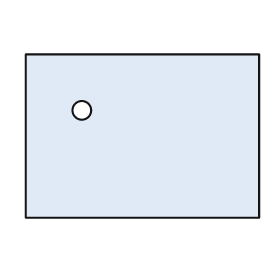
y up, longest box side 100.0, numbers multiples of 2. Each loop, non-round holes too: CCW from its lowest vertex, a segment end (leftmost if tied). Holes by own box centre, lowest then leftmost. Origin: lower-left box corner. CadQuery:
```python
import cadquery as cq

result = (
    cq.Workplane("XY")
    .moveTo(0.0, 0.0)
    .lineTo(100.0, 0.0)
    .lineTo(100.0, 70.0)
    .lineTo(0.0, 70.0)
    .close()
    .moveTo(24.0, 46.0)
    .circle(4.0)
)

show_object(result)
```